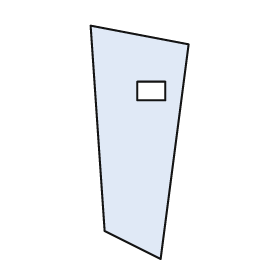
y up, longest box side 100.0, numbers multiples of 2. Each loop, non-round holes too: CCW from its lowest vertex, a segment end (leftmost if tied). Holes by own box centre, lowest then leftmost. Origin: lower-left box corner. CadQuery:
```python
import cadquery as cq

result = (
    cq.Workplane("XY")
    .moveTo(30.0, 0.0)
    .lineTo(42.0, 92.0)
    .lineTo(0.0, 100.0)
    .lineTo(6.0, 12.0)
    .close()
    .moveTo(20.0, 68.0)
    .lineTo(32.0, 68.0)
    .lineTo(32.0, 76.0)
    .lineTo(20.0, 76.0)
    .close()
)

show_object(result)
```